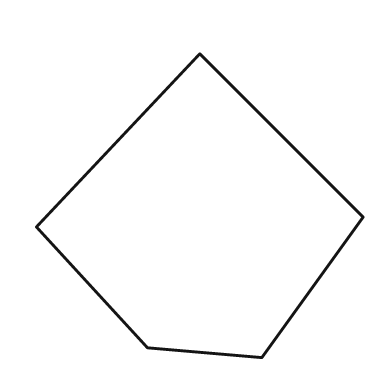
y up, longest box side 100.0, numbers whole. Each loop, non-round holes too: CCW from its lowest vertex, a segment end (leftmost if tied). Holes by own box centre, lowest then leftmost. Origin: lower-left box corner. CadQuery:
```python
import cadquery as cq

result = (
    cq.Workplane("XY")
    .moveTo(69.0, 0.0)
    .lineTo(100.0, 43.0)
    .lineTo(50.0, 93.0)
    .lineTo(0.0, 40.0)
    .lineTo(34.0, 3.0)
    .close()
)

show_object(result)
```